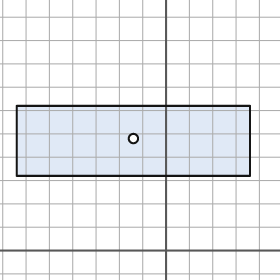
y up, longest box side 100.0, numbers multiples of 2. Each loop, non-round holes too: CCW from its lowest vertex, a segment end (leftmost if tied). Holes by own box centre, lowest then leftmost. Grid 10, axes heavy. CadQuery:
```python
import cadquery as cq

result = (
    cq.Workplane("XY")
    .moveTo(-64.0, 32.0)
    .lineTo(36.0, 32.0)
    .lineTo(36.0, 62.0)
    .lineTo(-64.0, 62.0)
    .close()
    .moveTo(-14.0, 48.0)
    .circle(2.0)
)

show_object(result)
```